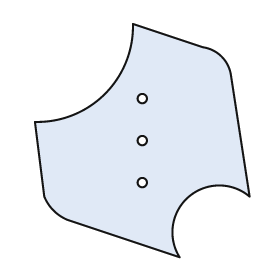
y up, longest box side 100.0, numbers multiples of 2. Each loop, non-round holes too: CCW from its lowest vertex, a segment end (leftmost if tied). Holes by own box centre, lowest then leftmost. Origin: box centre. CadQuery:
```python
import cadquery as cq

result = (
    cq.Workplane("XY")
    .moveTo(16.0, -50.0)
    .threePointArc((20.0, -24.0), (46.0, -24.0))
    .lineTo(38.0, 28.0)
    .threePointArc((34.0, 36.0), (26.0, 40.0))
    .lineTo(-4.0, 50.0)
    .threePointArc((-16.0, 20.0), (-46.0, 8.0))
    .lineTo(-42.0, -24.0)
    .threePointArc((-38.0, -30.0), (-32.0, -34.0))
    .close()
    .moveTo(0.0, -18.0)
    .circle(2.0)
    .moveTo(0.0, 0.0)
    .circle(2.0)
    .moveTo(0.0, 18.0)
    .circle(2.0)
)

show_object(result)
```